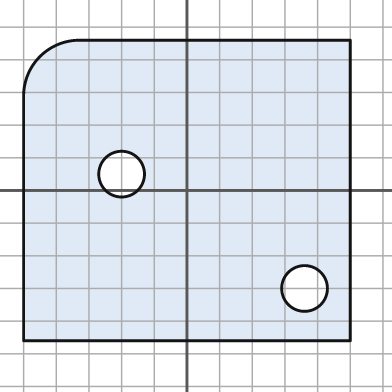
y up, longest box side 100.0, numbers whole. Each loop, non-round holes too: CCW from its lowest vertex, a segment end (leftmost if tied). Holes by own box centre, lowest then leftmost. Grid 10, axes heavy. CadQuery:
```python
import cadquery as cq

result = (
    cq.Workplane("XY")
    .moveTo(-50.0, -46.0)
    .lineTo(50.0, -46.0)
    .lineTo(50.0, 46.0)
    .lineTo(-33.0, 46.0)
    .threePointArc((-45.0, 41.0), (-50.0, 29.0))
    .close()
    .moveTo(36.0, -30.0)
    .circle(7.0)
    .moveTo(-20.0, 5.0)
    .circle(7.0)
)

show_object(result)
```